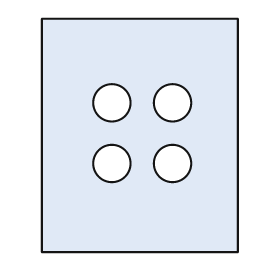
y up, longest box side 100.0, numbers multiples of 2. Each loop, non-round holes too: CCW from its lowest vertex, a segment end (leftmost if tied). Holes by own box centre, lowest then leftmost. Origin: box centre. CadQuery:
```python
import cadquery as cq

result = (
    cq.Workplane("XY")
    .moveTo(-42.0, -50.0)
    .lineTo(42.0, -50.0)
    .lineTo(42.0, 50.0)
    .lineTo(-42.0, 50.0)
    .close()
    .moveTo(-12.0, -12.0)
    .circle(8.0)
    .moveTo(14.0, -12.0)
    .circle(8.0)
    .moveTo(-12.0, 14.0)
    .circle(8.0)
    .moveTo(14.0, 14.0)
    .circle(8.0)
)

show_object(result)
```